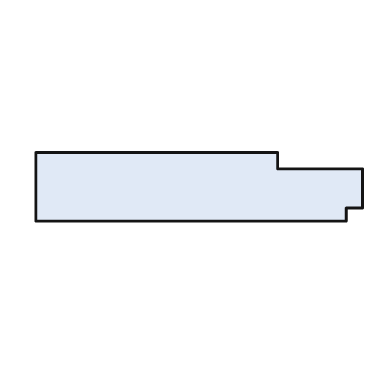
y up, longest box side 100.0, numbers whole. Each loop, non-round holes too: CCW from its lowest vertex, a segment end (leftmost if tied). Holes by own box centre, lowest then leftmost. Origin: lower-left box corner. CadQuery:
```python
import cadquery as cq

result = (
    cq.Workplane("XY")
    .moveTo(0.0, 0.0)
    .lineTo(95.0, 0.0)
    .lineTo(95.0, 4.0)
    .lineTo(100.0, 4.0)
    .lineTo(100.0, 16.0)
    .lineTo(74.0, 16.0)
    .lineTo(74.0, 21.0)
    .lineTo(0.0, 21.0)
    .close()
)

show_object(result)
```